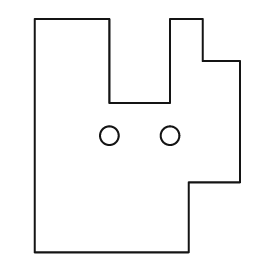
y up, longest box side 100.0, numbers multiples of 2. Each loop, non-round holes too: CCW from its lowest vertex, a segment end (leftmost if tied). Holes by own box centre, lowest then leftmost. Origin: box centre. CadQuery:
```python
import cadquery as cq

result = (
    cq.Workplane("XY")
    .moveTo(-44.0, -50.0)
    .lineTo(22.0, -50.0)
    .lineTo(22.0, -20.0)
    .lineTo(44.0, -20.0)
    .lineTo(44.0, 32.0)
    .lineTo(28.0, 32.0)
    .lineTo(28.0, 50.0)
    .lineTo(14.0, 50.0)
    .lineTo(14.0, 14.0)
    .lineTo(-12.0, 14.0)
    .lineTo(-12.0, 50.0)
    .lineTo(-44.0, 50.0)
    .close()
    .moveTo(-12.0, 0.0)
    .circle(4.0)
    .moveTo(14.0, 0.0)
    .circle(4.0)
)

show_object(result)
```